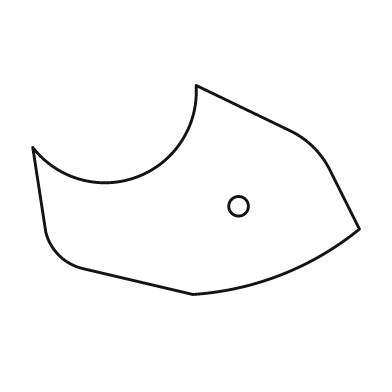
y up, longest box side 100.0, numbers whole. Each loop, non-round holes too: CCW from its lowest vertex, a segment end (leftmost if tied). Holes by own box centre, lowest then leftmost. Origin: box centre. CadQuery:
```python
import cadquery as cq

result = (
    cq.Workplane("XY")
    .moveTo(-1.0, -32.0)
    .threePointArc((26.0, -26.0), (50.0, -12.0))
    .lineTo(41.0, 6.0)
    .threePointArc((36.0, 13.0), (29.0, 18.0))
    .lineTo(0.0, 32.0)
    .threePointArc((-18.0, 4.0), (-50.0, 13.0))
    .lineTo(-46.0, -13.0)
    .threePointArc((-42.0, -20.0), (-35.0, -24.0))
    .close()
    .moveTo(13.0, -5.0)
    .circle(3.0)
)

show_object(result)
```